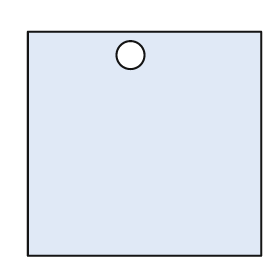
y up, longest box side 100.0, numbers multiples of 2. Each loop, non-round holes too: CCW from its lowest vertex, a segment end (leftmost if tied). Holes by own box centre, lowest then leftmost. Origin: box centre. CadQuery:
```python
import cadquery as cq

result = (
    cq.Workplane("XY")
    .moveTo(-50.0, -48.0)
    .lineTo(50.0, -48.0)
    .lineTo(50.0, 48.0)
    .lineTo(-50.0, 48.0)
    .close()
    .moveTo(-6.0, 38.0)
    .circle(6.0)
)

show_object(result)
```